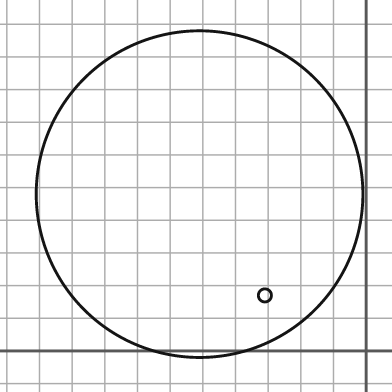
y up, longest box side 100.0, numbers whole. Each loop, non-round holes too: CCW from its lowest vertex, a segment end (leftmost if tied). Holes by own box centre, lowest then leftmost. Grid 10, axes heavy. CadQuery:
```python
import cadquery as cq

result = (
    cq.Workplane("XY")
    .moveTo(-51.0, 48.0)
    .circle(50.0)
    .moveTo(-31.0, 17.0)
    .circle(2.0)
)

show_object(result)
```